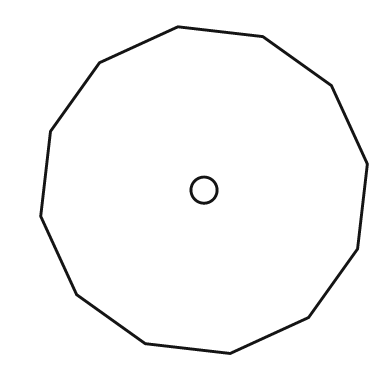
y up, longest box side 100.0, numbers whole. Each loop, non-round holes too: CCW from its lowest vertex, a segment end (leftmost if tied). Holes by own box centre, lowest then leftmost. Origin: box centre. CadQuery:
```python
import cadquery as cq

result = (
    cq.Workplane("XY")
    .moveTo(8.0, -50.0)
    .lineTo(32.0, -39.0)
    .lineTo(47.0, -18.0)
    .lineTo(50.0, 8.0)
    .lineTo(39.0, 32.0)
    .lineTo(18.0, 47.0)
    .lineTo(-8.0, 50.0)
    .lineTo(-32.0, 39.0)
    .lineTo(-47.0, 18.0)
    .lineTo(-50.0, -8.0)
    .lineTo(-39.0, -32.0)
    .lineTo(-18.0, -47.0)
    .close()
    .moveTo(0.0, 0.0)
    .circle(4.0)
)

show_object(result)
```